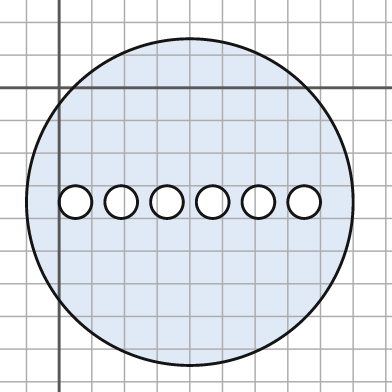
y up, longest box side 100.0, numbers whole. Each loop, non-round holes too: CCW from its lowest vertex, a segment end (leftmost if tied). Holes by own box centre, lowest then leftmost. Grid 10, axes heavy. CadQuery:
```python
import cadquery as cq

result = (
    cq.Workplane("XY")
    .moveTo(40.0, -35.0)
    .circle(50.0)
    .moveTo(5.0, -35.0)
    .circle(5.0)
    .moveTo(19.0, -35.0)
    .circle(5.0)
    .moveTo(33.0, -35.0)
    .circle(5.0)
    .moveTo(47.0, -35.0)
    .circle(5.0)
    .moveTo(61.0, -35.0)
    .circle(5.0)
    .moveTo(75.0, -35.0)
    .circle(5.0)
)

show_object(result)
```